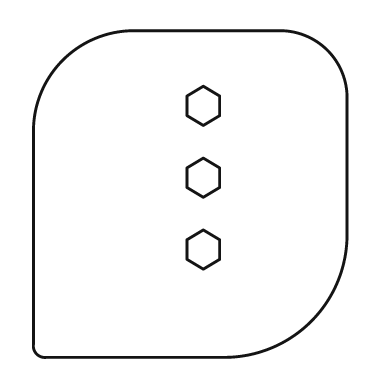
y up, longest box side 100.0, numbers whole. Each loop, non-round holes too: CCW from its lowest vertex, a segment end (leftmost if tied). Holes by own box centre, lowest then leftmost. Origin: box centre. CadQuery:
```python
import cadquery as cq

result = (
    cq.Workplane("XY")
    .moveTo(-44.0, -50.0)
    .lineTo(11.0, -50.0)
    .threePointArc((37.0, -39.0), (48.0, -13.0))
    .lineTo(48.0, 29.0)
    .threePointArc((42.0, 44.0), (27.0, 50.0))
    .lineTo(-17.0, 50.0)
    .threePointArc((-39.0, 41.0), (-48.0, 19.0))
    .lineTo(-48.0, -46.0)
    .threePointArc((-47.0, -49.0), (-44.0, -50.0))
    .close()
    .moveTo(4.0, -23.0)
    .lineTo(9.0, -20.0)
    .lineTo(9.0, -14.0)
    .lineTo(4.0, -11.0)
    .lineTo(-1.0, -14.0)
    .lineTo(-1.0, -20.0)
    .close()
    .moveTo(4.0, -1.0)
    .lineTo(9.0, 2.0)
    .lineTo(9.0, 8.0)
    .lineTo(4.0, 11.0)
    .lineTo(-1.0, 8.0)
    .lineTo(-1.0, 2.0)
    .close()
    .moveTo(4.0, 21.0)
    .lineTo(9.0, 24.0)
    .lineTo(9.0, 30.0)
    .lineTo(4.0, 33.0)
    .lineTo(-1.0, 30.0)
    .lineTo(-1.0, 24.0)
    .close()
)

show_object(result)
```